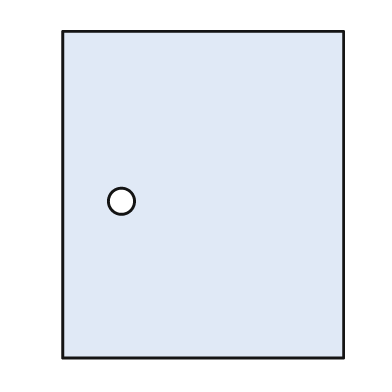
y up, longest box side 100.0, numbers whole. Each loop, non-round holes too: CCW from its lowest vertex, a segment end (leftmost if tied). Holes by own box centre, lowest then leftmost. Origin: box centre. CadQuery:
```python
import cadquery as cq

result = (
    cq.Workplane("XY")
    .moveTo(-43.0, -50.0)
    .lineTo(43.0, -50.0)
    .lineTo(43.0, 50.0)
    .lineTo(-43.0, 50.0)
    .close()
    .moveTo(-25.0, -2.0)
    .circle(4.0)
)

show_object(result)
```